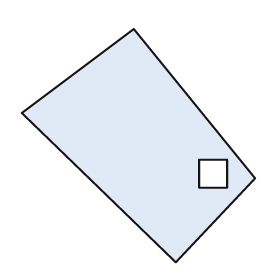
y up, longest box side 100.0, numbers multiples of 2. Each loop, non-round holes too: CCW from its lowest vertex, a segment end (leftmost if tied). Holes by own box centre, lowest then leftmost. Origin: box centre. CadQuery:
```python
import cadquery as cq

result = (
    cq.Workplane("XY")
    .moveTo(16.0, -50.0)
    .lineTo(50.0, -14.0)
    .lineTo(-2.0, 50.0)
    .lineTo(-50.0, 14.0)
    .close()
    .moveTo(26.0, -18.0)
    .lineTo(38.0, -18.0)
    .lineTo(38.0, -6.0)
    .lineTo(26.0, -6.0)
    .close()
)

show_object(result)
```